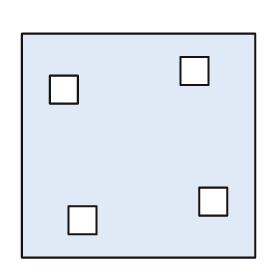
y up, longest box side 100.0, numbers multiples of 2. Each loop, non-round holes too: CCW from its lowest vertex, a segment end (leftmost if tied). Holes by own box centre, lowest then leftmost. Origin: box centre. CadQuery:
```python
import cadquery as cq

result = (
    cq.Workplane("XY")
    .moveTo(-50.0, -48.0)
    .lineTo(50.0, -48.0)
    .lineTo(50.0, 48.0)
    .lineTo(-50.0, 48.0)
    .close()
    .moveTo(-30.0, -38.0)
    .lineTo(-18.0, -38.0)
    .lineTo(-18.0, -26.0)
    .lineTo(-30.0, -26.0)
    .close()
    .moveTo(26.0, -30.0)
    .lineTo(38.0, -30.0)
    .lineTo(38.0, -18.0)
    .lineTo(26.0, -18.0)
    .close()
    .moveTo(-38.0, 18.0)
    .lineTo(-26.0, 18.0)
    .lineTo(-26.0, 30.0)
    .lineTo(-38.0, 30.0)
    .close()
    .moveTo(18.0, 26.0)
    .lineTo(30.0, 26.0)
    .lineTo(30.0, 38.0)
    .lineTo(18.0, 38.0)
    .close()
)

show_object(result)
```